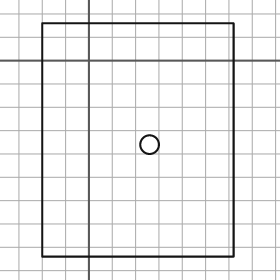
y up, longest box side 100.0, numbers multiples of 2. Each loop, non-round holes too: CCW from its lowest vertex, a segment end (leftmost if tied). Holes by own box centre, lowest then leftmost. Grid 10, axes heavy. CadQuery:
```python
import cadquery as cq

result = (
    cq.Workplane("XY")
    .moveTo(-20.0, -84.0)
    .lineTo(62.0, -84.0)
    .lineTo(62.0, 16.0)
    .lineTo(-20.0, 16.0)
    .close()
    .moveTo(26.0, -36.0)
    .circle(4.0)
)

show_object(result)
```